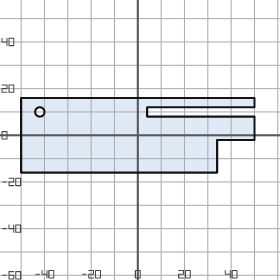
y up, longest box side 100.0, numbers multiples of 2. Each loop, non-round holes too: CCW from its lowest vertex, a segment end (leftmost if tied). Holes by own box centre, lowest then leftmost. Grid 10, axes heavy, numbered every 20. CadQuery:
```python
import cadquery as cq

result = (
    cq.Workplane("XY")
    .moveTo(-50.0, -16.0)
    .lineTo(34.0, -16.0)
    .lineTo(34.0, -2.0)
    .lineTo(50.0, -2.0)
    .lineTo(50.0, 8.0)
    .lineTo(4.0, 8.0)
    .lineTo(4.0, 12.0)
    .lineTo(50.0, 12.0)
    .lineTo(50.0, 16.0)
    .lineTo(-50.0, 16.0)
    .close()
    .moveTo(-42.0, 10.0)
    .circle(2.0)
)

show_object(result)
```